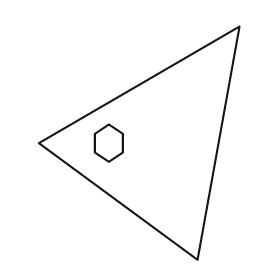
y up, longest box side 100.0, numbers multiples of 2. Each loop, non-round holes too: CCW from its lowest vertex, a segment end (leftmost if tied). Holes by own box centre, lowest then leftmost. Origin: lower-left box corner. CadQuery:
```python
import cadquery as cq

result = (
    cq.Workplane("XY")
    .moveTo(68.0, 0.0)
    .lineTo(86.0, 100.0)
    .lineTo(0.0, 50.0)
    .close()
    .moveTo(30.0, 42.0)
    .lineTo(36.0, 46.0)
    .lineTo(36.0, 54.0)
    .lineTo(30.0, 58.0)
    .lineTo(24.0, 54.0)
    .lineTo(24.0, 46.0)
    .close()
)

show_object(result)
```